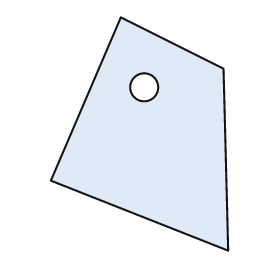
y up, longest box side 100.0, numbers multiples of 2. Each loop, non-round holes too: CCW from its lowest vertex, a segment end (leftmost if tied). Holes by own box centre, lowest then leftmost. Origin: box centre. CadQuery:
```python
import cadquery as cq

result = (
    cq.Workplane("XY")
    .moveTo(38.0, -50.0)
    .lineTo(36.0, 28.0)
    .lineTo(-8.0, 50.0)
    .lineTo(-38.0, -20.0)
    .close()
    .moveTo(2.0, 20.0)
    .circle(6.0)
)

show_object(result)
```